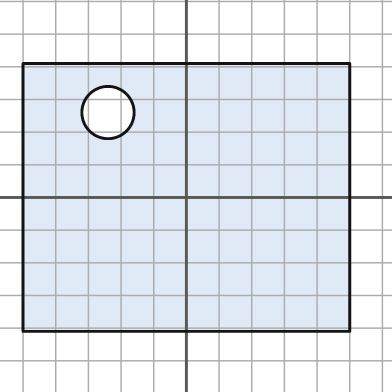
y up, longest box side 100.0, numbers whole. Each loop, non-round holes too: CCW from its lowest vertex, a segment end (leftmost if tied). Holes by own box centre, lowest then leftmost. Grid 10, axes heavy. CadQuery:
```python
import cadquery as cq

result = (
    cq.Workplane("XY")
    .moveTo(-50.0, -41.0)
    .lineTo(50.0, -41.0)
    .lineTo(50.0, 41.0)
    .lineTo(-50.0, 41.0)
    .close()
    .moveTo(-24.0, 26.0)
    .circle(8.0)
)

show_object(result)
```